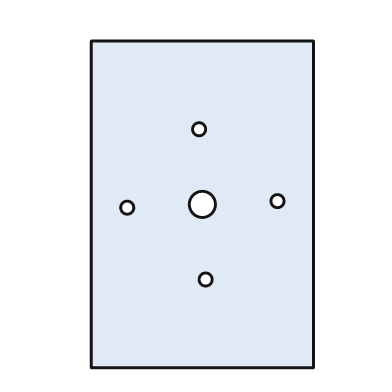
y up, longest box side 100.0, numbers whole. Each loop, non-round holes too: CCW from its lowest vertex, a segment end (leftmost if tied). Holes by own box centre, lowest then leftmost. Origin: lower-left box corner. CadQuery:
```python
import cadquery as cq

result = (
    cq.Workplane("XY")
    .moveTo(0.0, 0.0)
    .lineTo(68.0, 0.0)
    .lineTo(68.0, 100.0)
    .lineTo(0.0, 100.0)
    .close()
    .moveTo(35.0, 27.0)
    .circle(2.0)
    .moveTo(11.0, 49.0)
    .circle(2.0)
    .moveTo(34.0, 50.0)
    .circle(4.0)
    .moveTo(57.0, 51.0)
    .circle(2.0)
    .moveTo(33.0, 73.0)
    .circle(2.0)
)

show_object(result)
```